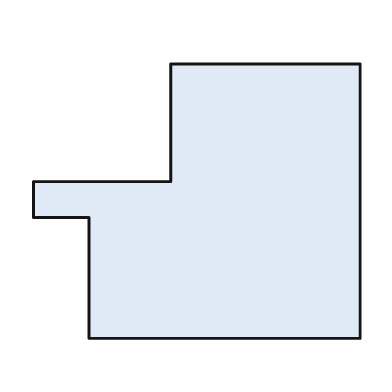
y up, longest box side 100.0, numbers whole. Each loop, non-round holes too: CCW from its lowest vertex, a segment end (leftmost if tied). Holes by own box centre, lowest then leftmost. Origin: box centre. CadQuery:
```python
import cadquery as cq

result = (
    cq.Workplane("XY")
    .moveTo(-33.0, -42.0)
    .lineTo(50.0, -42.0)
    .lineTo(50.0, 42.0)
    .lineTo(-8.0, 42.0)
    .lineTo(-8.0, 6.0)
    .lineTo(-50.0, 6.0)
    .lineTo(-50.0, -5.0)
    .lineTo(-33.0, -5.0)
    .close()
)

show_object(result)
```